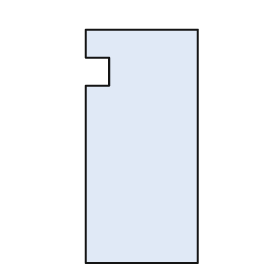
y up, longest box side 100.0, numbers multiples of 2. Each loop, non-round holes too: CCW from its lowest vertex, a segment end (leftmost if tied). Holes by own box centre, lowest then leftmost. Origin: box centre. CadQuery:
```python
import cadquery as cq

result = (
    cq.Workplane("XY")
    .moveTo(-24.0, -50.0)
    .lineTo(24.0, -50.0)
    .lineTo(24.0, 50.0)
    .lineTo(-24.0, 50.0)
    .lineTo(-24.0, 38.0)
    .lineTo(-14.0, 38.0)
    .lineTo(-14.0, 26.0)
    .lineTo(-24.0, 26.0)
    .close()
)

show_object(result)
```